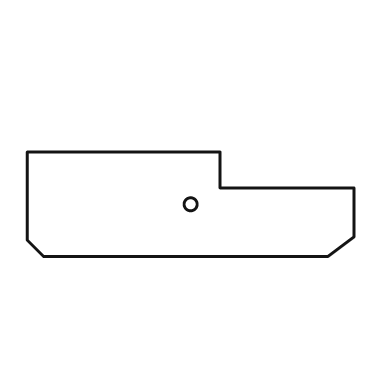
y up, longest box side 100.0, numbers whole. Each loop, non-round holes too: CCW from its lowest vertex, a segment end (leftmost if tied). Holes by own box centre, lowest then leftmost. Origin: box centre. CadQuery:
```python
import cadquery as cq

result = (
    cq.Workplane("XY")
    .moveTo(-45.0, -16.0)
    .lineTo(42.0, -16.0)
    .lineTo(50.0, -10.0)
    .lineTo(50.0, 5.0)
    .lineTo(9.0, 5.0)
    .lineTo(9.0, 16.0)
    .lineTo(-50.0, 16.0)
    .lineTo(-50.0, -11.0)
    .close()
    .moveTo(0.0, 0.0)
    .circle(2.0)
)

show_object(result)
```